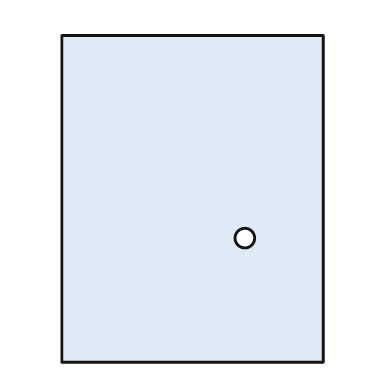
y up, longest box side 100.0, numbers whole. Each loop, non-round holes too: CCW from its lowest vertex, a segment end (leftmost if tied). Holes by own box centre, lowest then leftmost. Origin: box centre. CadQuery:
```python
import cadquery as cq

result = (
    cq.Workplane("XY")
    .moveTo(-40.0, -50.0)
    .lineTo(40.0, -50.0)
    .lineTo(40.0, 50.0)
    .lineTo(-40.0, 50.0)
    .close()
    .moveTo(16.0, -12.0)
    .circle(3.0)
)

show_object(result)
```